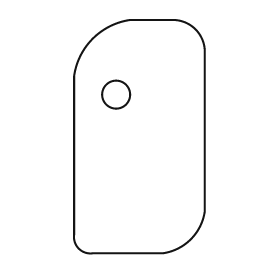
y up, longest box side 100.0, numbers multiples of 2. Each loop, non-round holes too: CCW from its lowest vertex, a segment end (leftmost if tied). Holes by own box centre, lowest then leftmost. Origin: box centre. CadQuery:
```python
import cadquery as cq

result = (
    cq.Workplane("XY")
    .moveTo(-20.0, -50.0)
    .lineTo(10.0, -50.0)
    .threePointArc((22.0, -44.0), (28.0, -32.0))
    .lineTo(28.0, 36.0)
    .threePointArc((24.0, 46.0), (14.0, 50.0))
    .lineTo(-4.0, 50.0)
    .threePointArc((-20.0, 42.0), (-28.0, 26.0))
    .lineTo(-28.0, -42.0)
    .threePointArc((-26.0, -48.0), (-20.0, -50.0))
    .close()
    .moveTo(-10.0, 18.0)
    .circle(6.0)
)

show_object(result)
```